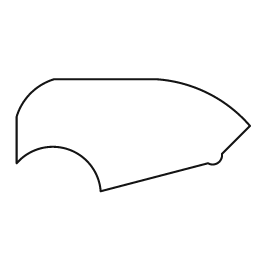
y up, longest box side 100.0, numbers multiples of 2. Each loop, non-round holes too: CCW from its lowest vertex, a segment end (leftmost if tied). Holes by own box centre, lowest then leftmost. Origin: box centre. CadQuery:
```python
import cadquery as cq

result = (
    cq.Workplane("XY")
    .moveTo(-14.0, -24.0)
    .lineTo(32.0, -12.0)
    .threePointArc((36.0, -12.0), (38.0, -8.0))
    .lineTo(50.0, 4.0)
    .threePointArc((32.0, 18.0), (10.0, 24.0))
    .lineTo(-34.0, 24.0)
    .threePointArc((-44.0, 18.0), (-50.0, 8.0))
    .lineTo(-50.0, -12.0)
    .threePointArc((-28.0, -6.0), (-14.0, -24.0))
    .close()
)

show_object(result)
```